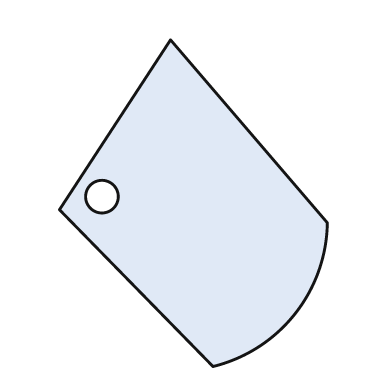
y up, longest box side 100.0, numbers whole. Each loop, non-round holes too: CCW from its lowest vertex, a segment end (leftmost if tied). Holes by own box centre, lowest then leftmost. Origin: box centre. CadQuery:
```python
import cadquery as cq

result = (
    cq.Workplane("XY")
    .moveTo(6.0, -50.0)
    .threePointArc((31.0, -34.0), (41.0, -6.0))
    .lineTo(-7.0, 50.0)
    .lineTo(-41.0, -2.0)
    .close()
    .moveTo(-28.0, 2.0)
    .circle(5.0)
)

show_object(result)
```